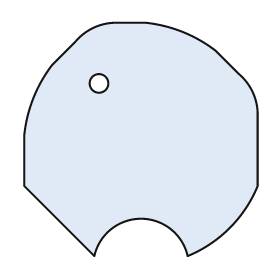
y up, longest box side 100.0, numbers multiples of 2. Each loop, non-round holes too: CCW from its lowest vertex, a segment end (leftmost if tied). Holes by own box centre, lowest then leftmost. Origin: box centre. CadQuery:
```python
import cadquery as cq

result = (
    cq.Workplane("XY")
    .moveTo(-20.0, -50.0)
    .threePointArc((0.0, -34.0), (20.0, -50.0))
    .threePointArc((38.0, -38.0), (50.0, -20.0))
    .lineTo(50.0, 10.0)
    .threePointArc((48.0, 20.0), (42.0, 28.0))
    .lineTo(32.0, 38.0)
    .threePointArc((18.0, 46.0), (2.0, 50.0))
    .lineTo(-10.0, 50.0)
    .threePointArc((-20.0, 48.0), (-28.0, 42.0))
    .lineTo(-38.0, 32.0)
    .threePointArc((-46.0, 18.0), (-50.0, 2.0))
    .lineTo(-50.0, -20.0)
    .close()
    .moveTo(-18.0, 24.0)
    .circle(4.0)
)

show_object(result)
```